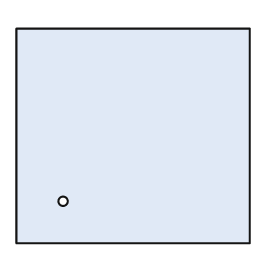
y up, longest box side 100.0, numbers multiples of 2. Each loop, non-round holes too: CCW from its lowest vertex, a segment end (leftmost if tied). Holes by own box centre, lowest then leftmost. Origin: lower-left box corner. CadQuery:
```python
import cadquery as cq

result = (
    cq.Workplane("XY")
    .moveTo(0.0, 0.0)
    .lineTo(100.0, 0.0)
    .lineTo(100.0, 92.0)
    .lineTo(0.0, 92.0)
    .close()
    .moveTo(20.0, 18.0)
    .circle(2.0)
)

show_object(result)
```